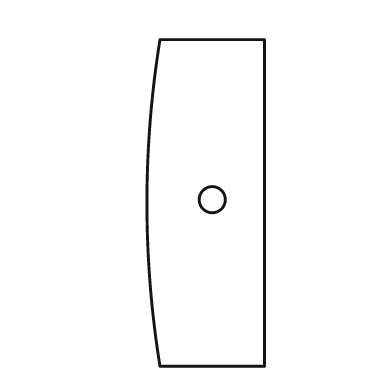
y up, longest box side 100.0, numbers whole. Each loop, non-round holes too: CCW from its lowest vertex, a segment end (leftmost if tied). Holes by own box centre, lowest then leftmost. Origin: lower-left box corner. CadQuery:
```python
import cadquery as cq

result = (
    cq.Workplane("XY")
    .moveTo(4.0, 0.0)
    .lineTo(36.0, 0.0)
    .lineTo(36.0, 100.0)
    .lineTo(4.0, 100.0)
    .threePointArc((0.0, 50.0), (4.0, 0.0))
    .close()
    .moveTo(20.0, 51.0)
    .circle(4.0)
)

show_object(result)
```